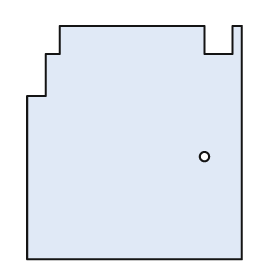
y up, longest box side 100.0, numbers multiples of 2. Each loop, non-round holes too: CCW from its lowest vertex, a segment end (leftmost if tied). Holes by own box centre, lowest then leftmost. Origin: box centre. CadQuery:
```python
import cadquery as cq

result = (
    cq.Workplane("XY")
    .moveTo(-46.0, -50.0)
    .lineTo(46.0, -50.0)
    .lineTo(46.0, 50.0)
    .lineTo(42.0, 50.0)
    .lineTo(42.0, 38.0)
    .lineTo(30.0, 38.0)
    .lineTo(30.0, 50.0)
    .lineTo(-32.0, 50.0)
    .lineTo(-32.0, 38.0)
    .lineTo(-38.0, 38.0)
    .lineTo(-38.0, 20.0)
    .lineTo(-46.0, 20.0)
    .close()
    .moveTo(30.0, -6.0)
    .circle(2.0)
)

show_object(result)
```